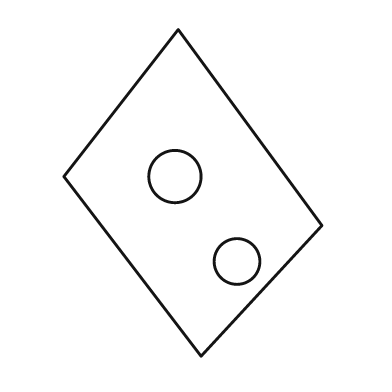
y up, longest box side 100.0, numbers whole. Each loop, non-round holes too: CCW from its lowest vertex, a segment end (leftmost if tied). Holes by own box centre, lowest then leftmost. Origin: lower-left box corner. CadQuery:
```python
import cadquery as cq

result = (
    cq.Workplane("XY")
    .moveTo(42.0, 0.0)
    .lineTo(79.0, 40.0)
    .lineTo(35.0, 100.0)
    .lineTo(0.0, 55.0)
    .close()
    .moveTo(53.0, 29.0)
    .circle(7.0)
    .moveTo(34.0, 55.0)
    .circle(8.0)
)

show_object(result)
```